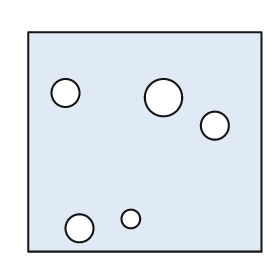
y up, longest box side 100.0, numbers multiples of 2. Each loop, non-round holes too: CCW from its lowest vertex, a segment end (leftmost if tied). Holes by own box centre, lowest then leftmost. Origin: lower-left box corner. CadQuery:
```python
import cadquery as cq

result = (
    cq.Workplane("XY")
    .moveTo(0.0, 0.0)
    .lineTo(100.0, 0.0)
    .lineTo(100.0, 94.0)
    .lineTo(0.0, 94.0)
    .close()
    .moveTo(22.0, 10.0)
    .circle(6.0)
    .moveTo(44.0, 14.0)
    .circle(4.0)
    .moveTo(80.0, 54.0)
    .circle(6.0)
    .moveTo(58.0, 66.0)
    .circle(8.0)
    .moveTo(16.0, 68.0)
    .circle(6.0)
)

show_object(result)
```